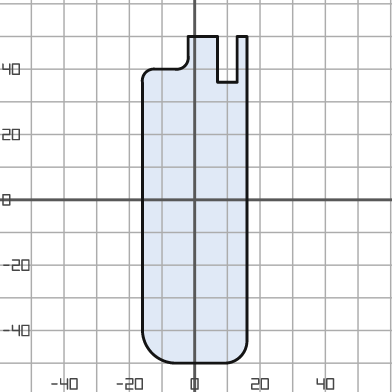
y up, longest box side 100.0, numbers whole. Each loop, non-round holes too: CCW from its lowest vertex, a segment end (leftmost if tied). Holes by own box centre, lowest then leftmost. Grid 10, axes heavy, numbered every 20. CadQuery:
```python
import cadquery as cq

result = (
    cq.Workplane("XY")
    .moveTo(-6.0, -50.0)
    .lineTo(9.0, -50.0)
    .threePointArc((14.0, -48.0), (16.0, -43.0))
    .lineTo(16.0, 50.0)
    .lineTo(13.0, 50.0)
    .lineTo(13.0, 36.0)
    .lineTo(7.0, 36.0)
    .lineTo(7.0, 50.0)
    .lineTo(-2.0, 50.0)
    .lineTo(-2.0, 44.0)
    .threePointArc((-3.0, 41.0), (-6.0, 40.0))
    .lineTo(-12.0, 40.0)
    .threePointArc((-15.0, 39.0), (-16.0, 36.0))
    .lineTo(-16.0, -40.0)
    .threePointArc((-13.0, -47.0), (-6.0, -50.0))
    .close()
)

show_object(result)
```